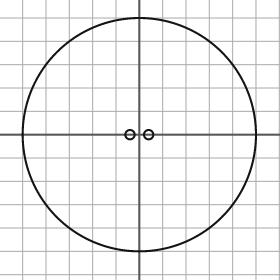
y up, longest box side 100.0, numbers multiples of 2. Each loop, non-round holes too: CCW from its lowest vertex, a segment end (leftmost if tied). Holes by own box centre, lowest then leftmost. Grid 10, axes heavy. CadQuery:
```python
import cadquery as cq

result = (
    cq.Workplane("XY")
    .moveTo(0.0, 0.0)
    .circle(50.0)
    .moveTo(-4.0, 0.0)
    .circle(2.0)
    .moveTo(4.0, 0.0)
    .circle(2.0)
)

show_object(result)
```